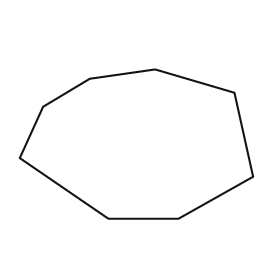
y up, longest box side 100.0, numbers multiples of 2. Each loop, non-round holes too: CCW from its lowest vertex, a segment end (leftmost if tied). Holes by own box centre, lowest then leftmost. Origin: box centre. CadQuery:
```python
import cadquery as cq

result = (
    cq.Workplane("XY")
    .moveTo(-12.0, -32.0)
    .lineTo(18.0, -32.0)
    .lineTo(50.0, -14.0)
    .lineTo(42.0, 22.0)
    .lineTo(8.0, 32.0)
    .lineTo(-20.0, 28.0)
    .lineTo(-40.0, 16.0)
    .lineTo(-50.0, -6.0)
    .close()
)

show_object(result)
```